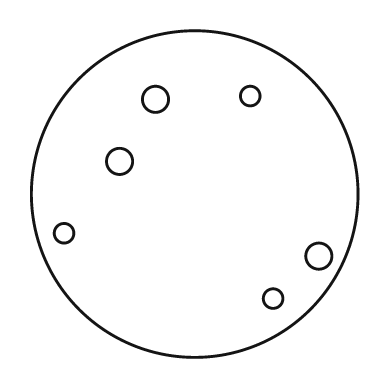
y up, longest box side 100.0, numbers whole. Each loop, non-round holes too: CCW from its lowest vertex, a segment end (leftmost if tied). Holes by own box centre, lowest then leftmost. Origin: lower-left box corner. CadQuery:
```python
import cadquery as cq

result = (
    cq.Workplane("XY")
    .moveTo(50.0, 50.0)
    .circle(50.0)
    .moveTo(74.0, 18.0)
    .circle(3.0)
    .moveTo(88.0, 31.0)
    .circle(4.0)
    .moveTo(10.0, 38.0)
    .circle(3.0)
    .moveTo(27.0, 60.0)
    .circle(4.0)
    .moveTo(38.0, 79.0)
    .circle(4.0)
    .moveTo(67.0, 80.0)
    .circle(3.0)
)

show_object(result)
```